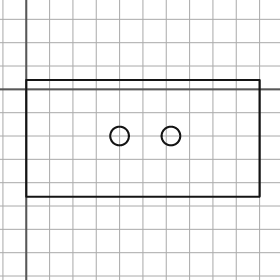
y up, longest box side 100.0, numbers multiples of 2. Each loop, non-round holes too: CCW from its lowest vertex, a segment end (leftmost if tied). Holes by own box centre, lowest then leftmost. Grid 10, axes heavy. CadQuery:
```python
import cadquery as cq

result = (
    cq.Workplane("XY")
    .moveTo(0.0, -46.0)
    .lineTo(100.0, -46.0)
    .lineTo(100.0, 4.0)
    .lineTo(0.0, 4.0)
    .close()
    .moveTo(40.0, -20.0)
    .circle(4.0)
    .moveTo(62.0, -20.0)
    .circle(4.0)
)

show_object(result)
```